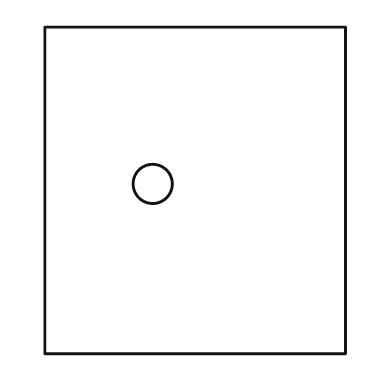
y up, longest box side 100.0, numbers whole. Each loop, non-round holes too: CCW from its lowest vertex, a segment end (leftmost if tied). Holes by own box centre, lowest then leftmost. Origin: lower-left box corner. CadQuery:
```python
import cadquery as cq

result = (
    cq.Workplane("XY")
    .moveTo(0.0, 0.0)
    .lineTo(92.0, 0.0)
    .lineTo(92.0, 100.0)
    .lineTo(0.0, 100.0)
    .close()
    .moveTo(33.0, 52.0)
    .circle(6.0)
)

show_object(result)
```